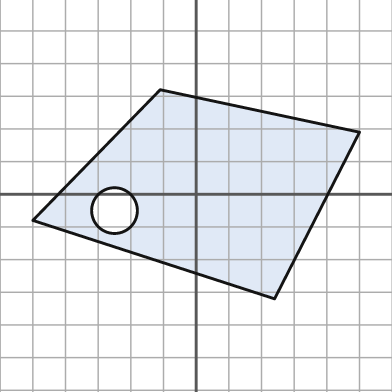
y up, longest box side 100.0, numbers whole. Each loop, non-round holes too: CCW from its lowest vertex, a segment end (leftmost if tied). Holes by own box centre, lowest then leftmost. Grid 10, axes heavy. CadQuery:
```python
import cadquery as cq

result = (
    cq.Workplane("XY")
    .moveTo(24.0, -32.0)
    .lineTo(50.0, 19.0)
    .lineTo(-11.0, 32.0)
    .lineTo(-50.0, -8.0)
    .close()
    .moveTo(-25.0, -5.0)
    .circle(7.0)
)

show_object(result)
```